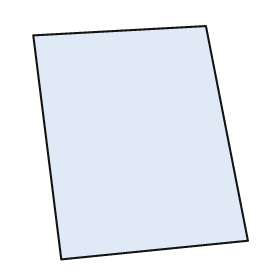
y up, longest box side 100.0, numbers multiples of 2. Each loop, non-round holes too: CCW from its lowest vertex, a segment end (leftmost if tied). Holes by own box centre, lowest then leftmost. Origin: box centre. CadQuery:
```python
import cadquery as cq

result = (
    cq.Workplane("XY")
    .moveTo(-34.0, -50.0)
    .lineTo(46.0, -42.0)
    .lineTo(28.0, 50.0)
    .lineTo(-46.0, 46.0)
    .close()
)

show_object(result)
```